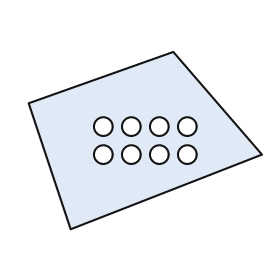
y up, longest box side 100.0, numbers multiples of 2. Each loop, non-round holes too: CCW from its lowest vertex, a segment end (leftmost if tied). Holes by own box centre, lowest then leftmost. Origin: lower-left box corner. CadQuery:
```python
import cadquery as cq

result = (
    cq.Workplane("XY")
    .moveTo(18.0, 0.0)
    .lineTo(100.0, 32.0)
    .lineTo(62.0, 76.0)
    .lineTo(0.0, 54.0)
    .close()
    .moveTo(32.0, 32.0)
    .circle(4.0)
    .moveTo(44.0, 32.0)
    .circle(4.0)
    .moveTo(56.0, 32.0)
    .circle(4.0)
    .moveTo(68.0, 32.0)
    .circle(4.0)
    .moveTo(32.0, 44.0)
    .circle(4.0)
    .moveTo(44.0, 44.0)
    .circle(4.0)
    .moveTo(56.0, 44.0)
    .circle(4.0)
    .moveTo(68.0, 44.0)
    .circle(4.0)
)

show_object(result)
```